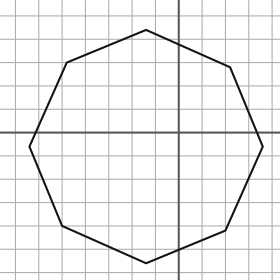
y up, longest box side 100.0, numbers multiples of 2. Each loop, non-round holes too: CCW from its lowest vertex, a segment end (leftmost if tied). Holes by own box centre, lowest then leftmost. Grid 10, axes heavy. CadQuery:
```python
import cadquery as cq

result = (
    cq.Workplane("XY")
    .moveTo(-14.0, -56.0)
    .lineTo(20.0, -42.0)
    .lineTo(36.0, -6.0)
    .lineTo(22.0, 28.0)
    .lineTo(-14.0, 44.0)
    .lineTo(-48.0, 30.0)
    .lineTo(-64.0, -6.0)
    .lineTo(-50.0, -40.0)
    .close()
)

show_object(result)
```